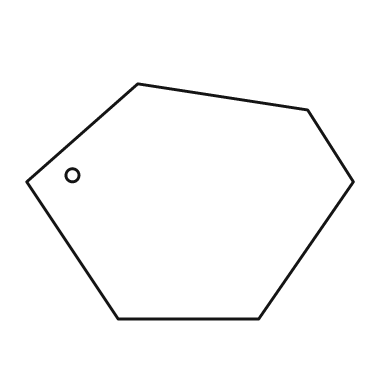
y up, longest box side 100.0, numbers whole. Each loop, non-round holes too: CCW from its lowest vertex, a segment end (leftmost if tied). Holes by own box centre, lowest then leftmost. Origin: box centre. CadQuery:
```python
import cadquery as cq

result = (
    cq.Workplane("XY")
    .moveTo(-22.0, -36.0)
    .lineTo(21.0, -36.0)
    .lineTo(50.0, 6.0)
    .lineTo(36.0, 28.0)
    .lineTo(-16.0, 36.0)
    .lineTo(-50.0, 6.0)
    .close()
    .moveTo(-36.0, 8.0)
    .circle(2.0)
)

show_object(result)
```